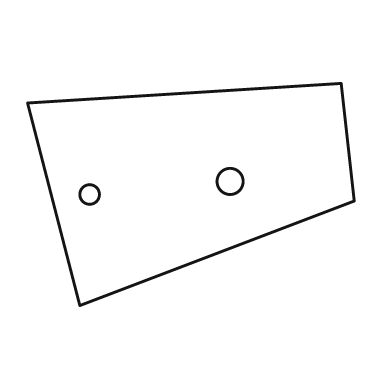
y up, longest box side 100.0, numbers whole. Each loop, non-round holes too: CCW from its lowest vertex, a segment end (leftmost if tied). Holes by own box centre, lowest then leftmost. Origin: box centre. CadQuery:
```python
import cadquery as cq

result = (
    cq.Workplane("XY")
    .moveTo(-34.0, -34.0)
    .lineTo(50.0, -2.0)
    .lineTo(46.0, 34.0)
    .lineTo(-50.0, 28.0)
    .close()
    .moveTo(-31.0, 0.0)
    .circle(3.0)
    .moveTo(12.0, 4.0)
    .circle(4.0)
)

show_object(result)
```